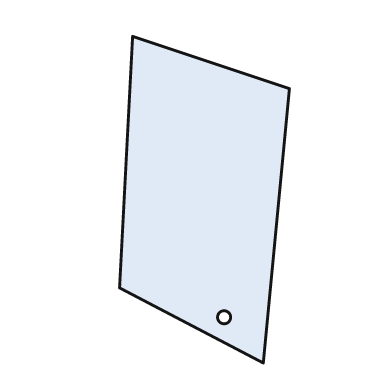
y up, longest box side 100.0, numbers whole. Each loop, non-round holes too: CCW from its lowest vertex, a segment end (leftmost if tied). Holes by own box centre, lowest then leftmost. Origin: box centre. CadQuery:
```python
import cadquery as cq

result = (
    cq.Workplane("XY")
    .moveTo(18.0, -50.0)
    .lineTo(26.0, 34.0)
    .lineTo(-22.0, 50.0)
    .lineTo(-26.0, -27.0)
    .close()
    .moveTo(6.0, -36.0)
    .circle(2.0)
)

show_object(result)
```